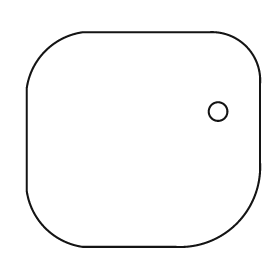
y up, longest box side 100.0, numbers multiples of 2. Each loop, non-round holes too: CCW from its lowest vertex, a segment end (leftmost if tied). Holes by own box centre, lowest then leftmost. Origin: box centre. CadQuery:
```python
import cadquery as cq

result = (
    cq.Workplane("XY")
    .moveTo(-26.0, -46.0)
    .lineTo(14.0, -46.0)
    .threePointArc((40.0, -36.0), (50.0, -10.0))
    .lineTo(50.0, 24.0)
    .threePointArc((44.0, 40.0), (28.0, 46.0))
    .lineTo(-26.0, 46.0)
    .threePointArc((-42.0, 38.0), (-50.0, 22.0))
    .lineTo(-50.0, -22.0)
    .threePointArc((-42.0, -38.0), (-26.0, -46.0))
    .close()
    .moveTo(32.0, 12.0)
    .circle(4.0)
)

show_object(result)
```